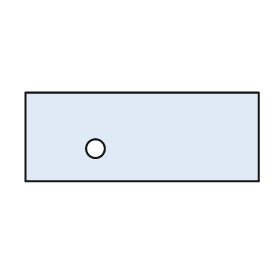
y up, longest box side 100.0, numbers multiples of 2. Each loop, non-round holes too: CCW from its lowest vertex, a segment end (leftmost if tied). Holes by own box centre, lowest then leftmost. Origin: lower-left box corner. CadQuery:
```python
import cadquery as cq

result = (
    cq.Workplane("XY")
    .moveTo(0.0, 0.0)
    .lineTo(100.0, 0.0)
    .lineTo(100.0, 38.0)
    .lineTo(0.0, 38.0)
    .close()
    .moveTo(30.0, 14.0)
    .circle(4.0)
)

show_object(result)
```